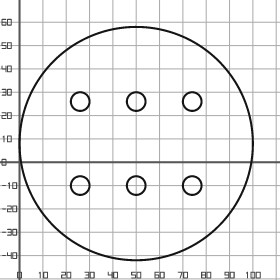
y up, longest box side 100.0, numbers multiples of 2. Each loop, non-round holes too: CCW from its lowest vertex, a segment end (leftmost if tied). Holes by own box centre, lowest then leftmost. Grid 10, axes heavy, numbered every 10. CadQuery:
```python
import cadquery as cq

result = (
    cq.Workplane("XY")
    .moveTo(50.0, 8.0)
    .circle(50.0)
    .moveTo(26.0, -10.0)
    .circle(4.0)
    .moveTo(50.0, -10.0)
    .circle(4.0)
    .moveTo(74.0, -10.0)
    .circle(4.0)
    .moveTo(26.0, 26.0)
    .circle(4.0)
    .moveTo(50.0, 26.0)
    .circle(4.0)
    .moveTo(74.0, 26.0)
    .circle(4.0)
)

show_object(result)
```